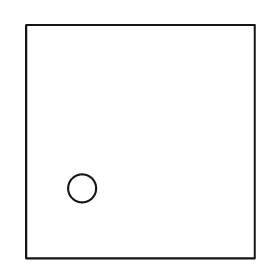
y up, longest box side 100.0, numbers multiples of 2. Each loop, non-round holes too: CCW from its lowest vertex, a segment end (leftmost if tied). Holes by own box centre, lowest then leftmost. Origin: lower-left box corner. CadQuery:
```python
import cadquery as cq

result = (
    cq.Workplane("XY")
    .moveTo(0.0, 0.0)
    .lineTo(98.0, 0.0)
    .lineTo(98.0, 100.0)
    .lineTo(0.0, 100.0)
    .close()
    .moveTo(24.0, 30.0)
    .circle(6.0)
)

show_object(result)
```